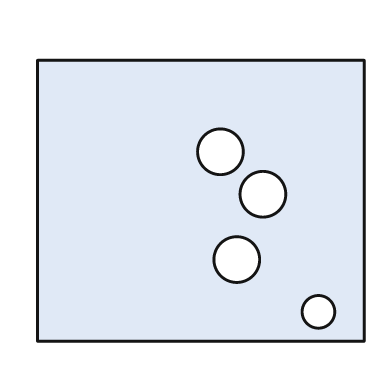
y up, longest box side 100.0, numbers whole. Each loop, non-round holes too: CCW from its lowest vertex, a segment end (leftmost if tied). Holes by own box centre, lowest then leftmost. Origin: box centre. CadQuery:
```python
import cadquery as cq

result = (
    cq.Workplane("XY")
    .moveTo(-50.0, -43.0)
    .lineTo(50.0, -43.0)
    .lineTo(50.0, 43.0)
    .lineTo(-50.0, 43.0)
    .close()
    .moveTo(36.0, -34.0)
    .circle(5.0)
    .moveTo(11.0, -18.0)
    .circle(7.0)
    .moveTo(19.0, 2.0)
    .circle(7.0)
    .moveTo(6.0, 15.0)
    .circle(7.0)
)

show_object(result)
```